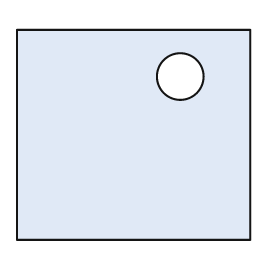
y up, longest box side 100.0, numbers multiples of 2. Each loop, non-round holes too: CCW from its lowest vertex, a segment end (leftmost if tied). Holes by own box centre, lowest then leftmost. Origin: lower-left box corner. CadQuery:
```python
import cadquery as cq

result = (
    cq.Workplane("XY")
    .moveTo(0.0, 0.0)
    .lineTo(100.0, 0.0)
    .lineTo(100.0, 90.0)
    .lineTo(0.0, 90.0)
    .close()
    .moveTo(70.0, 70.0)
    .circle(10.0)
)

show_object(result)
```